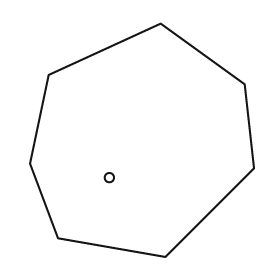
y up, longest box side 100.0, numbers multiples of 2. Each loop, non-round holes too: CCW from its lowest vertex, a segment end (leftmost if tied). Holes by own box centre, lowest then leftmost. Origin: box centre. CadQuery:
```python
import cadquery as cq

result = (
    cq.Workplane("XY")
    .moveTo(10.0, -50.0)
    .lineTo(48.0, -12.0)
    .lineTo(44.0, 24.0)
    .lineTo(8.0, 50.0)
    .lineTo(-40.0, 28.0)
    .lineTo(-48.0, -10.0)
    .lineTo(-36.0, -42.0)
    .close()
    .moveTo(-14.0, -16.0)
    .circle(2.0)
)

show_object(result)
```